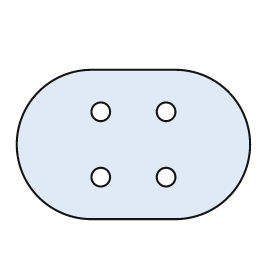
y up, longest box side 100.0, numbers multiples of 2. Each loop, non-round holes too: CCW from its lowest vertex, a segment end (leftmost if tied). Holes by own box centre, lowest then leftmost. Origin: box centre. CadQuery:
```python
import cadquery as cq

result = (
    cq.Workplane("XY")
    .moveTo(-18.0, -32.0)
    .lineTo(18.0, -32.0)
    .threePointArc((50.0, 0.0), (18.0, 32.0))
    .lineTo(-18.0, 32.0)
    .threePointArc((-50.0, 0.0), (-18.0, -32.0))
    .close()
    .moveTo(-14.0, -14.0)
    .circle(4.0)
    .moveTo(14.0, -14.0)
    .circle(4.0)
    .moveTo(-14.0, 14.0)
    .circle(4.0)
    .moveTo(14.0, 14.0)
    .circle(4.0)
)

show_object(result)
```